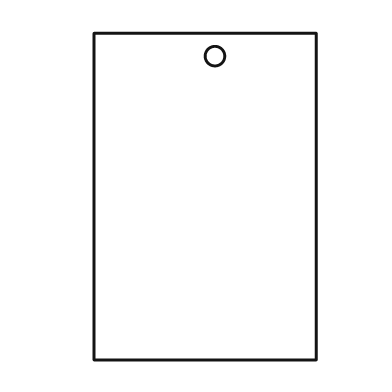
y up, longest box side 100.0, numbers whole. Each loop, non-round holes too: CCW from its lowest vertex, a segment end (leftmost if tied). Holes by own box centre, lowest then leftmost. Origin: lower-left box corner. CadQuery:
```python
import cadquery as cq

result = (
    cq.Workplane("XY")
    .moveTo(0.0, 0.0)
    .lineTo(68.0, 0.0)
    .lineTo(68.0, 100.0)
    .lineTo(0.0, 100.0)
    .close()
    .moveTo(37.0, 93.0)
    .circle(3.0)
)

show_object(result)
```